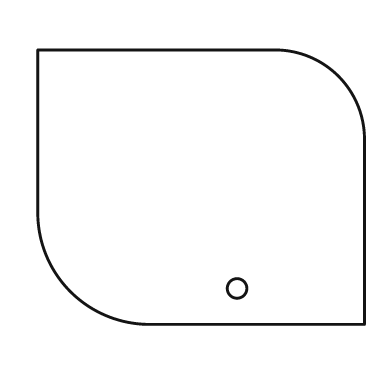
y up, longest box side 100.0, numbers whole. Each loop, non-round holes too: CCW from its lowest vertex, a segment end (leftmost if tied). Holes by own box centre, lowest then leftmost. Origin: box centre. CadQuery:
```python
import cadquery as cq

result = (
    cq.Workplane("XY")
    .moveTo(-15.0, -42.0)
    .lineTo(50.0, -42.0)
    .lineTo(50.0, 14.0)
    .threePointArc((42.0, 34.0), (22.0, 42.0))
    .lineTo(-50.0, 42.0)
    .lineTo(-50.0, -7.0)
    .threePointArc((-40.0, -32.0), (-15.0, -42.0))
    .close()
    .moveTo(11.0, -31.0)
    .circle(3.0)
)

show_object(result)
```